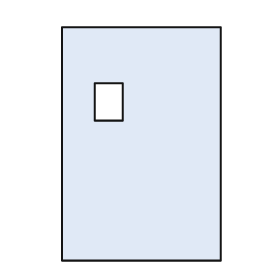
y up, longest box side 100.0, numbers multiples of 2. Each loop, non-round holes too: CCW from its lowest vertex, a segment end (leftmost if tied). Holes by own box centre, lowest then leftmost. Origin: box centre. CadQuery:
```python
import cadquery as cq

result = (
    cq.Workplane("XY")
    .moveTo(-34.0, -50.0)
    .lineTo(34.0, -50.0)
    .lineTo(34.0, 50.0)
    .lineTo(-34.0, 50.0)
    .close()
    .moveTo(-20.0, 10.0)
    .lineTo(-8.0, 10.0)
    .lineTo(-8.0, 26.0)
    .lineTo(-20.0, 26.0)
    .close()
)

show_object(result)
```